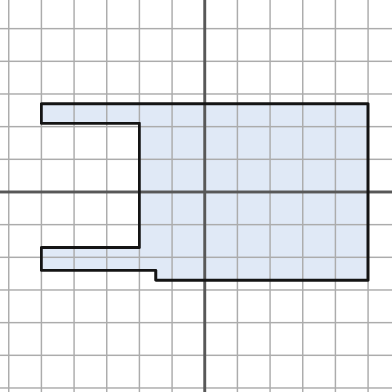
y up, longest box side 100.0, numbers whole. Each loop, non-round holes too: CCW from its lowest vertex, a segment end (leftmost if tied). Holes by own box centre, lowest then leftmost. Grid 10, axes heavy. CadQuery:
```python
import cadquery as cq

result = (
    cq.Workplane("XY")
    .moveTo(-15.0, -27.0)
    .lineTo(50.0, -27.0)
    .lineTo(50.0, 27.0)
    .lineTo(-50.0, 27.0)
    .lineTo(-50.0, 21.0)
    .lineTo(-20.0, 21.0)
    .lineTo(-20.0, -17.0)
    .lineTo(-50.0, -17.0)
    .lineTo(-50.0, -24.0)
    .lineTo(-15.0, -24.0)
    .close()
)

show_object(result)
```